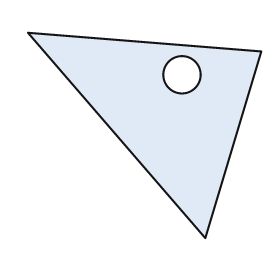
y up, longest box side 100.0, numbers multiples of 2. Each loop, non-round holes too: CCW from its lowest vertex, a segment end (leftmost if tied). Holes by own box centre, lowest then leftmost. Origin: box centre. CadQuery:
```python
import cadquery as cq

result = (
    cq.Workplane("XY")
    .moveTo(26.0, -44.0)
    .lineTo(50.0, 36.0)
    .lineTo(-50.0, 44.0)
    .close()
    .moveTo(16.0, 26.0)
    .circle(8.0)
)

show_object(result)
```